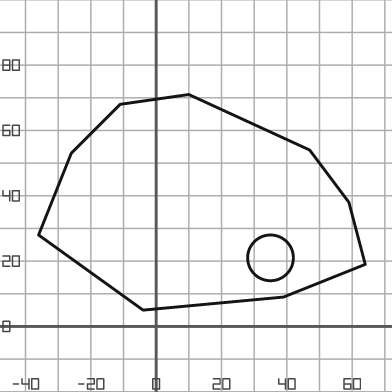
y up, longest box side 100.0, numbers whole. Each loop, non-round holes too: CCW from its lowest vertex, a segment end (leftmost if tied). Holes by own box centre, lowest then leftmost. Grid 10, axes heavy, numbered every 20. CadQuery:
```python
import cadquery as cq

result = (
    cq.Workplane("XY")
    .moveTo(-4.0, 5.0)
    .lineTo(39.0, 9.0)
    .lineTo(64.0, 19.0)
    .lineTo(59.0, 38.0)
    .lineTo(47.0, 54.0)
    .lineTo(10.0, 71.0)
    .lineTo(-11.0, 68.0)
    .lineTo(-26.0, 53.0)
    .lineTo(-36.0, 28.0)
    .close()
    .moveTo(35.0, 21.0)
    .circle(7.0)
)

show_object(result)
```